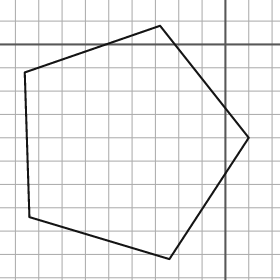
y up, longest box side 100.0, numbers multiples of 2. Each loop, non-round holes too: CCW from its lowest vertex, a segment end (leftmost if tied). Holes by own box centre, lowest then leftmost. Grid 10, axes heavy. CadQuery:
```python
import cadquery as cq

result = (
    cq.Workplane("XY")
    .moveTo(-24.0, -92.0)
    .lineTo(10.0, -40.0)
    .lineTo(-28.0, 8.0)
    .lineTo(-86.0, -12.0)
    .lineTo(-84.0, -74.0)
    .close()
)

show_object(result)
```